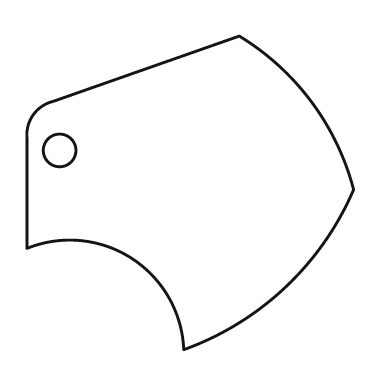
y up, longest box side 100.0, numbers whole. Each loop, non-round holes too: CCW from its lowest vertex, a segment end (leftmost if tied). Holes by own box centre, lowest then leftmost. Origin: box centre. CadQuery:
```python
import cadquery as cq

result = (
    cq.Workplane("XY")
    .moveTo(-2.0, -48.0)
    .threePointArc((29.0, -29.0), (50.0, 1.0))
    .threePointArc((37.0, 28.0), (15.0, 48.0))
    .lineTo(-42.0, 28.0)
    .threePointArc((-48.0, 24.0), (-50.0, 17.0))
    .lineTo(-50.0, -17.0)
    .threePointArc((-18.0, -20.0), (-2.0, -48.0))
    .close()
    .moveTo(-40.0, 13.0)
    .circle(5.0)
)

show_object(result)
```